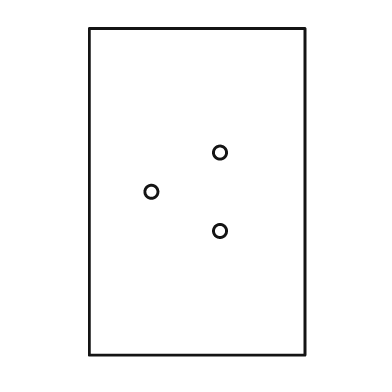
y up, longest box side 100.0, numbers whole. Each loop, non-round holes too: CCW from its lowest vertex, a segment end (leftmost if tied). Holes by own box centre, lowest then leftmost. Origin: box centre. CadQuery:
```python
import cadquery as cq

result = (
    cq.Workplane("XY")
    .moveTo(-33.0, -50.0)
    .lineTo(33.0, -50.0)
    .lineTo(33.0, 50.0)
    .lineTo(-33.0, 50.0)
    .close()
    .moveTo(7.0, -12.0)
    .circle(2.0)
    .moveTo(-14.0, 0.0)
    .circle(2.0)
    .moveTo(7.0, 12.0)
    .circle(2.0)
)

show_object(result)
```